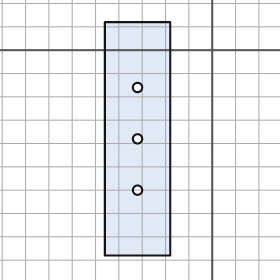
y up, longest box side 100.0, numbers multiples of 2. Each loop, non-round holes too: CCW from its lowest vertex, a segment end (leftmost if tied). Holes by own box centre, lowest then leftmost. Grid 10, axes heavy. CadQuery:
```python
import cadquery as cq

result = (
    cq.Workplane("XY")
    .moveTo(-46.0, -88.0)
    .lineTo(-18.0, -88.0)
    .lineTo(-18.0, 12.0)
    .lineTo(-46.0, 12.0)
    .close()
    .moveTo(-32.0, -60.0)
    .circle(2.0)
    .moveTo(-32.0, -38.0)
    .circle(2.0)
    .moveTo(-32.0, -16.0)
    .circle(2.0)
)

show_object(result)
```